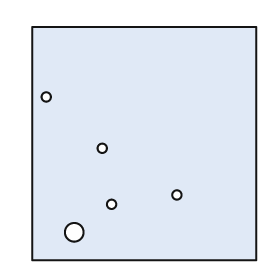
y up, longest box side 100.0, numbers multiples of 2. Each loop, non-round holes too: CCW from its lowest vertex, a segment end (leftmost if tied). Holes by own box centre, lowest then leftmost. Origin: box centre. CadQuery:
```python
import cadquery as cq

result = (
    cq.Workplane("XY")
    .moveTo(-48.0, -50.0)
    .lineTo(48.0, -50.0)
    .lineTo(48.0, 50.0)
    .lineTo(-48.0, 50.0)
    .close()
    .moveTo(-30.0, -38.0)
    .circle(4.0)
    .moveTo(-14.0, -26.0)
    .circle(2.0)
    .moveTo(14.0, -22.0)
    .circle(2.0)
    .moveTo(-18.0, -2.0)
    .circle(2.0)
    .moveTo(-42.0, 20.0)
    .circle(2.0)
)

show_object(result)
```